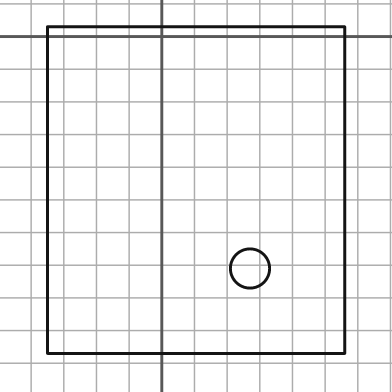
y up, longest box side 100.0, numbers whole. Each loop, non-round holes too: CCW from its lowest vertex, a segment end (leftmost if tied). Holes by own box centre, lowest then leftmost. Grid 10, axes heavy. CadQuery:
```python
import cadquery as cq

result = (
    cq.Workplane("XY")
    .moveTo(-35.0, -97.0)
    .lineTo(56.0, -97.0)
    .lineTo(56.0, 3.0)
    .lineTo(-35.0, 3.0)
    .close()
    .moveTo(27.0, -71.0)
    .circle(6.0)
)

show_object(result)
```